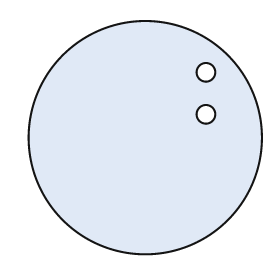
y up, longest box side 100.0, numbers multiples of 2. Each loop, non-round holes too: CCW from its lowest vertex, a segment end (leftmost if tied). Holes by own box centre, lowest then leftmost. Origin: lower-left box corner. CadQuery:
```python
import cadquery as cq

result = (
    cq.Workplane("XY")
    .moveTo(50.0, 50.0)
    .circle(50.0)
    .moveTo(76.0, 60.0)
    .circle(4.0)
    .moveTo(76.0, 78.0)
    .circle(4.0)
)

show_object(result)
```